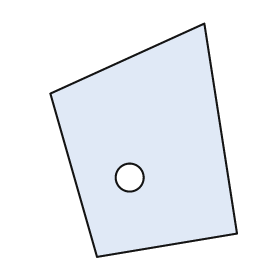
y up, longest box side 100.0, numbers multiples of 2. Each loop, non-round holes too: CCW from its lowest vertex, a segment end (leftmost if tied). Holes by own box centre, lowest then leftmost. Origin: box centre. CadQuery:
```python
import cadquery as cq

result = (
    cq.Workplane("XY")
    .moveTo(-20.0, -50.0)
    .lineTo(40.0, -40.0)
    .lineTo(26.0, 50.0)
    .lineTo(-40.0, 20.0)
    .close()
    .moveTo(-6.0, -16.0)
    .circle(6.0)
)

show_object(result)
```